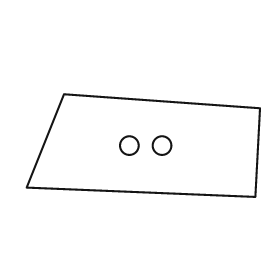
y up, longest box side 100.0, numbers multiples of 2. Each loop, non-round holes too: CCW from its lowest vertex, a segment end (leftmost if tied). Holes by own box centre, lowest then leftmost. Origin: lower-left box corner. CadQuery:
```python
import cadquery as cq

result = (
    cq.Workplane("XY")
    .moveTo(98.0, 0.0)
    .lineTo(100.0, 38.0)
    .lineTo(16.0, 44.0)
    .lineTo(0.0, 4.0)
    .close()
    .moveTo(44.0, 22.0)
    .circle(4.0)
    .moveTo(58.0, 22.0)
    .circle(4.0)
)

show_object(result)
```